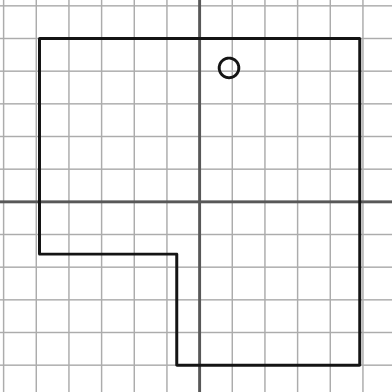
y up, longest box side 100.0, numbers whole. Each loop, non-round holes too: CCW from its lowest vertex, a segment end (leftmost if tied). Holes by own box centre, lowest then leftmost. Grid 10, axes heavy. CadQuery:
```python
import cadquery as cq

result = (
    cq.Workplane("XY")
    .moveTo(-7.0, -50.0)
    .lineTo(49.0, -50.0)
    .lineTo(49.0, 50.0)
    .lineTo(-49.0, 50.0)
    .lineTo(-49.0, -16.0)
    .lineTo(-7.0, -16.0)
    .close()
    .moveTo(9.0, 41.0)
    .circle(3.0)
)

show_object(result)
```